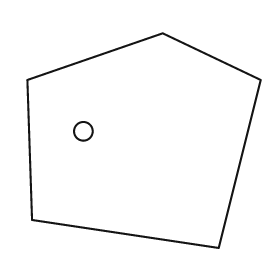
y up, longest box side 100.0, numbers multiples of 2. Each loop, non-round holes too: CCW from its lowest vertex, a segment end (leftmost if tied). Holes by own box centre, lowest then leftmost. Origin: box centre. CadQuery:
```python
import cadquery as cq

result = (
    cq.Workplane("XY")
    .moveTo(32.0, -46.0)
    .lineTo(50.0, 26.0)
    .lineTo(8.0, 46.0)
    .lineTo(-50.0, 26.0)
    .lineTo(-48.0, -34.0)
    .close()
    .moveTo(-26.0, 4.0)
    .circle(4.0)
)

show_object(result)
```